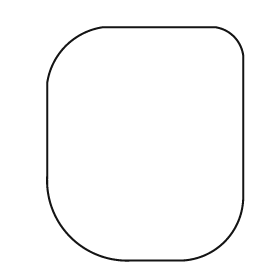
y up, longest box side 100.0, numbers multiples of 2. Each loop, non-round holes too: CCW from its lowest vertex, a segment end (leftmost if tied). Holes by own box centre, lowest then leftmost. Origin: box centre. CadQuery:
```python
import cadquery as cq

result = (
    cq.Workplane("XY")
    .moveTo(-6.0, -50.0)
    .lineTo(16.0, -50.0)
    .threePointArc((34.0, -42.0), (42.0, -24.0))
    .lineTo(42.0, 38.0)
    .threePointArc((38.0, 46.0), (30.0, 50.0))
    .lineTo(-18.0, 50.0)
    .threePointArc((-34.0, 42.0), (-42.0, 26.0))
    .lineTo(-42.0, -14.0)
    .threePointArc((-32.0, -40.0), (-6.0, -50.0))
    .close()
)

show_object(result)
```